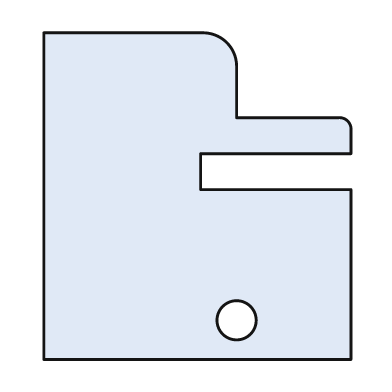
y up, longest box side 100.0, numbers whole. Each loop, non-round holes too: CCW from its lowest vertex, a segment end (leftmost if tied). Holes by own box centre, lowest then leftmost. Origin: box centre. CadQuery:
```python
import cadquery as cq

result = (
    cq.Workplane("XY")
    .moveTo(-47.0, -50.0)
    .lineTo(47.0, -50.0)
    .lineTo(47.0, 2.0)
    .lineTo(1.0, 2.0)
    .lineTo(1.0, 13.0)
    .lineTo(47.0, 13.0)
    .lineTo(47.0, 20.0)
    .threePointArc((46.0, 23.0), (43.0, 24.0))
    .lineTo(12.0, 24.0)
    .lineTo(12.0, 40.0)
    .threePointArc((9.0, 47.0), (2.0, 50.0))
    .lineTo(-47.0, 50.0)
    .close()
    .moveTo(12.0, -38.0)
    .circle(6.0)
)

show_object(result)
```